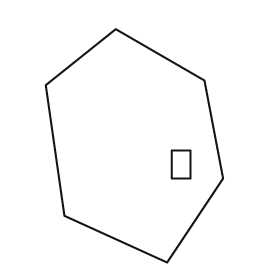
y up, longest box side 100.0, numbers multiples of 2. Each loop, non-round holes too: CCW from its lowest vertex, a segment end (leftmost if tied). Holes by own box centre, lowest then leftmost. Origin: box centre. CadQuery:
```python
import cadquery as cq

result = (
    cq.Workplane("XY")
    .moveTo(14.0, -50.0)
    .lineTo(38.0, -14.0)
    .lineTo(30.0, 28.0)
    .lineTo(-8.0, 50.0)
    .lineTo(-38.0, 26.0)
    .lineTo(-30.0, -30.0)
    .close()
    .moveTo(16.0, -14.0)
    .lineTo(24.0, -14.0)
    .lineTo(24.0, -2.0)
    .lineTo(16.0, -2.0)
    .close()
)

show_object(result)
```